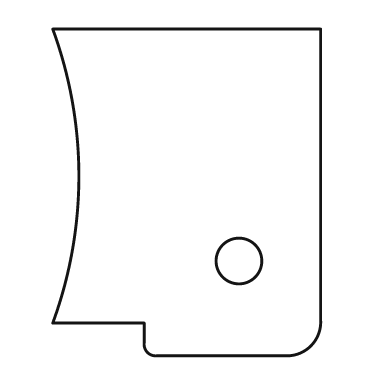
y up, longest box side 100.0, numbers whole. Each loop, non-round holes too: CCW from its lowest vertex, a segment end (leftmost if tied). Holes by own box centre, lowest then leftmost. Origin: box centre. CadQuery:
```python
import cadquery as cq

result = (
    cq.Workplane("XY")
    .moveTo(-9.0, -50.0)
    .lineTo(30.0, -50.0)
    .threePointArc((38.0, -47.0), (41.0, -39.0))
    .lineTo(41.0, 50.0)
    .lineTo(-41.0, 50.0)
    .threePointArc((-33.0, 5.0), (-41.0, -40.0))
    .lineTo(-13.0, -40.0)
    .lineTo(-13.0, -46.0)
    .threePointArc((-12.0, -49.0), (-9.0, -50.0))
    .close()
    .moveTo(16.0, -21.0)
    .circle(7.0)
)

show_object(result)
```